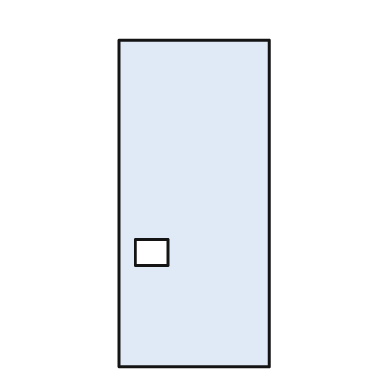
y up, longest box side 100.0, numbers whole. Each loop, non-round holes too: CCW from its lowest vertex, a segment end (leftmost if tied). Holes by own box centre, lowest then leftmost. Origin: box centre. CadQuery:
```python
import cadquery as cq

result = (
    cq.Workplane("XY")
    .moveTo(-23.0, -50.0)
    .lineTo(23.0, -50.0)
    .lineTo(23.0, 50.0)
    .lineTo(-23.0, 50.0)
    .close()
    .moveTo(-18.0, -19.0)
    .lineTo(-8.0, -19.0)
    .lineTo(-8.0, -11.0)
    .lineTo(-18.0, -11.0)
    .close()
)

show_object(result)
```